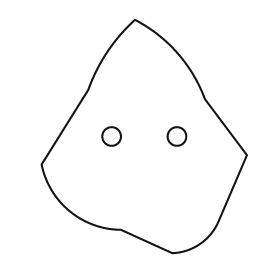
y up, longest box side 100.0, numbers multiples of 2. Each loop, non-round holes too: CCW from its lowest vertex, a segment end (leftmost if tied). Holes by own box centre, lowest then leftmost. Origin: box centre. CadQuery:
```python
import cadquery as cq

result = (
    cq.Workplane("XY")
    .moveTo(12.0, -50.0)
    .threePointArc((24.0, -46.0), (32.0, -36.0))
    .lineTo(44.0, -8.0)
    .lineTo(26.0, 16.0)
    .threePointArc((14.0, 36.0), (-4.0, 50.0))
    .threePointArc((-16.0, 36.0), (-24.0, 20.0))
    .lineTo(-44.0, -12.0)
    .threePointArc((-32.0, -32.0), (-10.0, -40.0))
    .close()
    .moveTo(-14.0, 0.0)
    .circle(4.0)
    .moveTo(14.0, 0.0)
    .circle(4.0)
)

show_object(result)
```